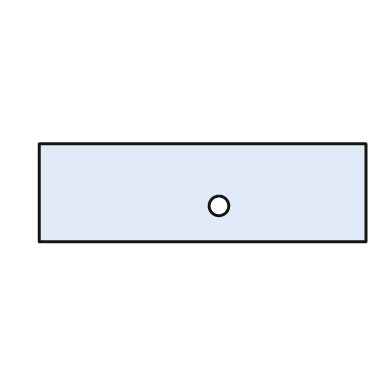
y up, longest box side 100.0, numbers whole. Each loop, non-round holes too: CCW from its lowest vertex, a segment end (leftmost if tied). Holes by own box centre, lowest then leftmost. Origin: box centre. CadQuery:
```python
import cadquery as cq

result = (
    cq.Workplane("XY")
    .moveTo(-50.0, -15.0)
    .lineTo(50.0, -15.0)
    .lineTo(50.0, 15.0)
    .lineTo(-50.0, 15.0)
    .close()
    .moveTo(5.0, -4.0)
    .circle(3.0)
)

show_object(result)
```